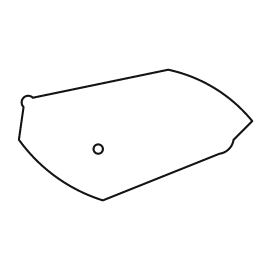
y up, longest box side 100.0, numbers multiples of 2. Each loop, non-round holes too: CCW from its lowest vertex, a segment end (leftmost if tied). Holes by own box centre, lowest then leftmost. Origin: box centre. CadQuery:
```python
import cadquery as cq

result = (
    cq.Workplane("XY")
    .moveTo(-14.0, -28.0)
    .lineTo(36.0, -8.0)
    .threePointArc((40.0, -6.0), (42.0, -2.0))
    .lineTo(50.0, 6.0)
    .threePointArc((34.0, 20.0), (14.0, 28.0))
    .lineTo(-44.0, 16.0)
    .threePointArc((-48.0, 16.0), (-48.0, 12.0))
    .lineTo(-50.0, -2.0)
    .threePointArc((-34.0, -18.0), (-14.0, -28.0))
    .close()
    .moveTo(-16.0, -6.0)
    .circle(2.0)
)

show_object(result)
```